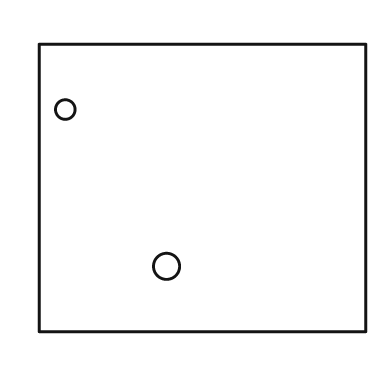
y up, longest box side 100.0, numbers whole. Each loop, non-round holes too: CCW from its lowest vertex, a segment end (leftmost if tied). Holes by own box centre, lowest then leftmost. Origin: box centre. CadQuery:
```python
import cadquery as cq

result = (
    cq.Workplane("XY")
    .moveTo(-50.0, -44.0)
    .lineTo(50.0, -44.0)
    .lineTo(50.0, 44.0)
    .lineTo(-50.0, 44.0)
    .close()
    .moveTo(-11.0, -24.0)
    .circle(4.0)
    .moveTo(-42.0, 24.0)
    .circle(3.0)
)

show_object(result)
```